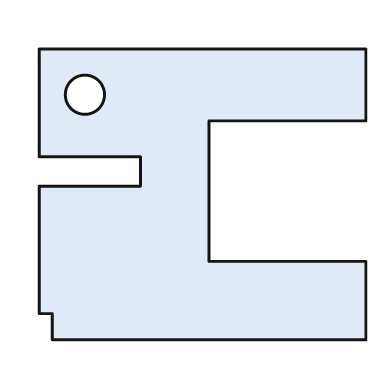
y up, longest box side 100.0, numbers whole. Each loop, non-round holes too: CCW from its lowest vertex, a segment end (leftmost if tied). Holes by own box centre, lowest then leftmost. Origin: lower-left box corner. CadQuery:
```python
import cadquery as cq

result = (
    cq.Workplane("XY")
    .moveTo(4.0, 0.0)
    .lineTo(100.0, 0.0)
    .lineTo(100.0, 24.0)
    .lineTo(52.0, 24.0)
    .lineTo(52.0, 67.0)
    .lineTo(100.0, 67.0)
    .lineTo(100.0, 89.0)
    .lineTo(0.0, 89.0)
    .lineTo(0.0, 56.0)
    .lineTo(31.0, 56.0)
    .lineTo(31.0, 47.0)
    .lineTo(0.0, 47.0)
    .lineTo(0.0, 8.0)
    .lineTo(4.0, 8.0)
    .close()
    .moveTo(14.0, 75.0)
    .circle(6.0)
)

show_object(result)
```